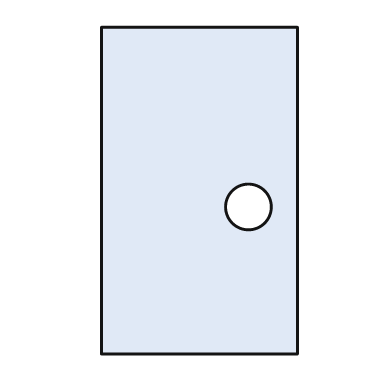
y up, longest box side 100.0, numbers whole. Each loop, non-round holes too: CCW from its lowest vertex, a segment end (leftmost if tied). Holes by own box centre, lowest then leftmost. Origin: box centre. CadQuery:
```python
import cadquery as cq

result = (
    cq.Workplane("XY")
    .moveTo(-30.0, -50.0)
    .lineTo(30.0, -50.0)
    .lineTo(30.0, 50.0)
    .lineTo(-30.0, 50.0)
    .close()
    .moveTo(15.0, -5.0)
    .circle(7.0)
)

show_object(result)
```